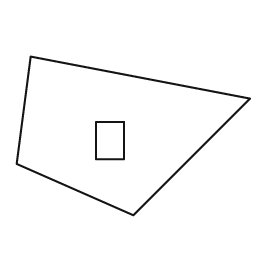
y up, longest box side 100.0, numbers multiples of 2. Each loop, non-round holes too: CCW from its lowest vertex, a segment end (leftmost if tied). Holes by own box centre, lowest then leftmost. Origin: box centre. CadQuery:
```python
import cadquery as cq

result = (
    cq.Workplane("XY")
    .moveTo(0.0, -34.0)
    .lineTo(50.0, 16.0)
    .lineTo(-44.0, 34.0)
    .lineTo(-50.0, -12.0)
    .close()
    .moveTo(-16.0, -10.0)
    .lineTo(-4.0, -10.0)
    .lineTo(-4.0, 6.0)
    .lineTo(-16.0, 6.0)
    .close()
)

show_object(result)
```